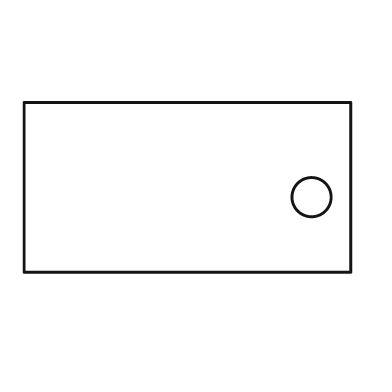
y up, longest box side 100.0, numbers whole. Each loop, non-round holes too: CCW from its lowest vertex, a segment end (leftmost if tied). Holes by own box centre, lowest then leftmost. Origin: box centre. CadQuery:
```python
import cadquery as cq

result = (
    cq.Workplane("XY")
    .moveTo(-50.0, -26.0)
    .lineTo(50.0, -26.0)
    .lineTo(50.0, 26.0)
    .lineTo(-50.0, 26.0)
    .close()
    .moveTo(38.0, -3.0)
    .circle(6.0)
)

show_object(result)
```